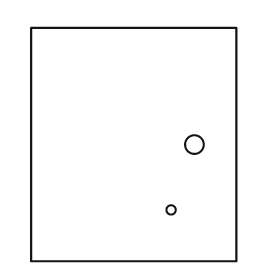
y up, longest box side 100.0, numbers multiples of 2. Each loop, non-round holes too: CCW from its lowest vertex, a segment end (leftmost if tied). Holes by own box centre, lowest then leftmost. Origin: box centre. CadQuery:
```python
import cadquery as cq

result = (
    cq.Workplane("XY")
    .moveTo(-44.0, -50.0)
    .lineTo(44.0, -50.0)
    .lineTo(44.0, 50.0)
    .lineTo(-44.0, 50.0)
    .close()
    .moveTo(16.0, -28.0)
    .circle(2.0)
    .moveTo(26.0, 0.0)
    .circle(4.0)
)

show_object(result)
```